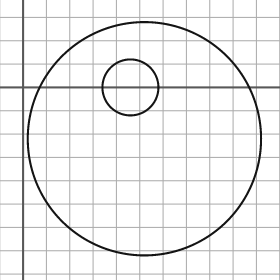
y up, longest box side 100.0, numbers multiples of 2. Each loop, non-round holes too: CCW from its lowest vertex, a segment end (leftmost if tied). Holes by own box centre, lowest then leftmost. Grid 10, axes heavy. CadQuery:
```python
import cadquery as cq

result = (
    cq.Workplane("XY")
    .moveTo(52.0, -22.0)
    .circle(50.0)
    .moveTo(46.0, 0.0)
    .circle(12.0)
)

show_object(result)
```